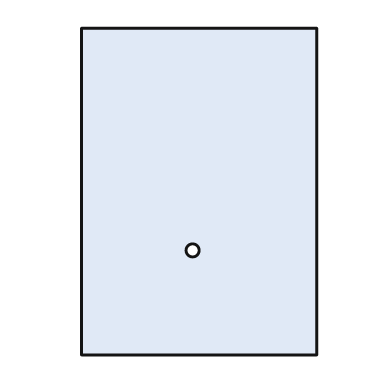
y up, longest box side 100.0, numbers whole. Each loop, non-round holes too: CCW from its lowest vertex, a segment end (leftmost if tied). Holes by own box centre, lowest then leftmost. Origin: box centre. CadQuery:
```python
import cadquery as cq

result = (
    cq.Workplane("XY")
    .moveTo(-36.0, -50.0)
    .lineTo(36.0, -50.0)
    .lineTo(36.0, 50.0)
    .lineTo(-36.0, 50.0)
    .close()
    .moveTo(-2.0, -18.0)
    .circle(2.0)
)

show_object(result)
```